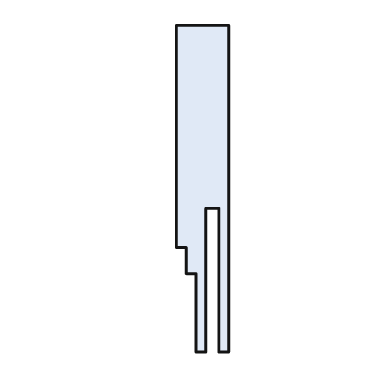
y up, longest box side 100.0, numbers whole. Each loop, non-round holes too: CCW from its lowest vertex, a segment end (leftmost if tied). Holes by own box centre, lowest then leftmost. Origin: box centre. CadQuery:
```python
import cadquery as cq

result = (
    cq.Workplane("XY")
    .moveTo(-2.0, -50.0)
    .lineTo(1.0, -50.0)
    .lineTo(1.0, -6.0)
    .lineTo(5.0, -6.0)
    .lineTo(5.0, -50.0)
    .lineTo(8.0, -50.0)
    .lineTo(8.0, 50.0)
    .lineTo(-8.0, 50.0)
    .lineTo(-8.0, -18.0)
    .lineTo(-5.0, -18.0)
    .lineTo(-5.0, -26.0)
    .lineTo(-2.0, -26.0)
    .close()
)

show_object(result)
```